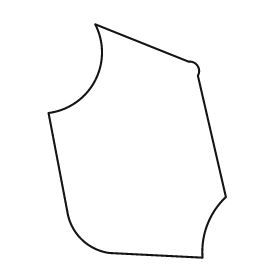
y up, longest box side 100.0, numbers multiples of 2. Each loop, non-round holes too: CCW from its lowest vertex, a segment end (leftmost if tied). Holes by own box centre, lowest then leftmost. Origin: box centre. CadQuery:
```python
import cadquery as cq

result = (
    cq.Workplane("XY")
    .moveTo(28.0, -50.0)
    .threePointArc((30.0, -36.0), (38.0, -24.0))
    .lineTo(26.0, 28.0)
    .threePointArc((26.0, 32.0), (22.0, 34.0))
    .lineTo(-18.0, 50.0)
    .threePointArc((-18.0, 26.0), (-38.0, 12.0))
    .lineTo(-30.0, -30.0)
    .threePointArc((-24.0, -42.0), (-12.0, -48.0))
    .close()
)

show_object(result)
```